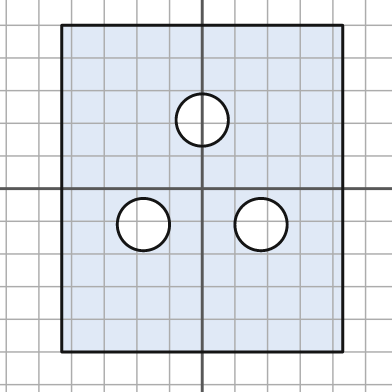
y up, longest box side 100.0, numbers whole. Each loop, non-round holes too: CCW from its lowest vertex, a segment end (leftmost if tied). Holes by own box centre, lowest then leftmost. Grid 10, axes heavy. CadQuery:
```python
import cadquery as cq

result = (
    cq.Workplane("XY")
    .moveTo(-43.0, -50.0)
    .lineTo(43.0, -50.0)
    .lineTo(43.0, 50.0)
    .lineTo(-43.0, 50.0)
    .close()
    .moveTo(-18.0, -11.0)
    .circle(8.0)
    .moveTo(18.0, -11.0)
    .circle(8.0)
    .moveTo(0.0, 21.0)
    .circle(8.0)
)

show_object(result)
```